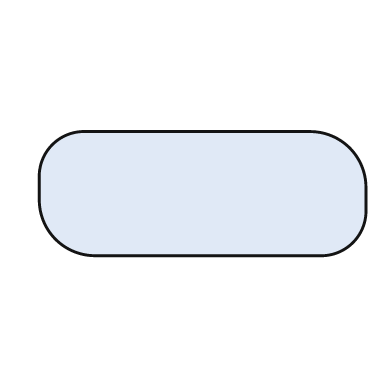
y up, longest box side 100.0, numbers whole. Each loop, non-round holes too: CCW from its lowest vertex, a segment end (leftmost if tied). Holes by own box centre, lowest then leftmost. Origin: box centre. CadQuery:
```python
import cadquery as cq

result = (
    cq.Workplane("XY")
    .moveTo(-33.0, -19.0)
    .lineTo(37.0, -19.0)
    .threePointArc((46.0, -15.0), (50.0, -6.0))
    .lineTo(50.0, 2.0)
    .threePointArc((45.0, 14.0), (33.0, 19.0))
    .lineTo(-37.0, 19.0)
    .threePointArc((-46.0, 15.0), (-50.0, 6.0))
    .lineTo(-50.0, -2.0)
    .threePointArc((-45.0, -14.0), (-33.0, -19.0))
    .close()
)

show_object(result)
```